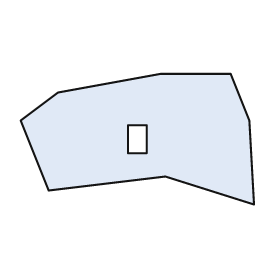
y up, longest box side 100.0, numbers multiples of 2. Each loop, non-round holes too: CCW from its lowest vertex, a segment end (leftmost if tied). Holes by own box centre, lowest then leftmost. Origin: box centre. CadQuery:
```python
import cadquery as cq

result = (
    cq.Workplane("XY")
    .moveTo(50.0, -28.0)
    .lineTo(48.0, 8.0)
    .lineTo(40.0, 28.0)
    .lineTo(10.0, 28.0)
    .lineTo(-34.0, 20.0)
    .lineTo(-50.0, 8.0)
    .lineTo(-38.0, -22.0)
    .lineTo(12.0, -16.0)
    .close()
    .moveTo(-4.0, -6.0)
    .lineTo(4.0, -6.0)
    .lineTo(4.0, 6.0)
    .lineTo(-4.0, 6.0)
    .close()
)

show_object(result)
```